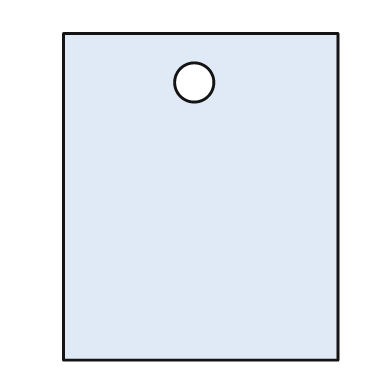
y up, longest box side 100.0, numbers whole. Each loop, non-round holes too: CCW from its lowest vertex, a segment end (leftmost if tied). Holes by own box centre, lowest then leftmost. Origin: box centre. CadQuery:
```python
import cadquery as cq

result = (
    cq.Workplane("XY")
    .moveTo(-42.0, -50.0)
    .lineTo(42.0, -50.0)
    .lineTo(42.0, 50.0)
    .lineTo(-42.0, 50.0)
    .close()
    .moveTo(-2.0, 35.0)
    .circle(6.0)
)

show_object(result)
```